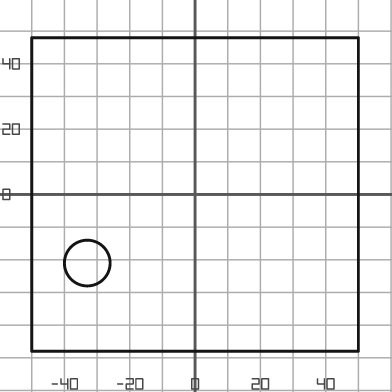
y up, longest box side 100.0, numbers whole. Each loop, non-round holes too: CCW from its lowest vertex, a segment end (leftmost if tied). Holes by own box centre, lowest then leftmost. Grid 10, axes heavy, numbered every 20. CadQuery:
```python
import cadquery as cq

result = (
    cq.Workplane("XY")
    .moveTo(-50.0, -48.0)
    .lineTo(50.0, -48.0)
    .lineTo(50.0, 48.0)
    .lineTo(-50.0, 48.0)
    .close()
    .moveTo(-33.0, -21.0)
    .circle(7.0)
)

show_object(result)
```